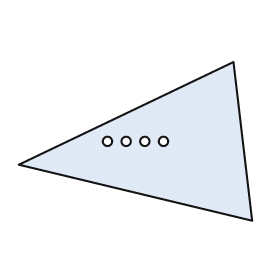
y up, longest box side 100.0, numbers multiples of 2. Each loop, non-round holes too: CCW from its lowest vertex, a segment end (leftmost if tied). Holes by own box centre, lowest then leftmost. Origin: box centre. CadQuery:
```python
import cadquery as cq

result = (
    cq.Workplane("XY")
    .moveTo(50.0, -34.0)
    .lineTo(42.0, 34.0)
    .lineTo(-50.0, -10.0)
    .close()
    .moveTo(-12.0, 0.0)
    .circle(2.0)
    .moveTo(-4.0, 0.0)
    .circle(2.0)
    .moveTo(4.0, 0.0)
    .circle(2.0)
    .moveTo(12.0, 0.0)
    .circle(2.0)
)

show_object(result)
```